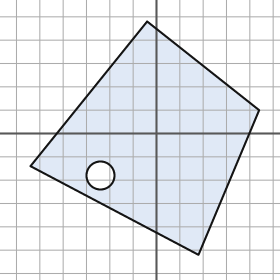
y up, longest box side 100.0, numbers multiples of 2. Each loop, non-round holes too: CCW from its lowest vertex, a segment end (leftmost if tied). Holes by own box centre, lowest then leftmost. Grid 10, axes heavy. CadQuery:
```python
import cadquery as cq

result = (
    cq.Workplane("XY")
    .moveTo(18.0, -52.0)
    .lineTo(44.0, 10.0)
    .lineTo(-4.0, 48.0)
    .lineTo(-54.0, -14.0)
    .close()
    .moveTo(-24.0, -18.0)
    .circle(6.0)
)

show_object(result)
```